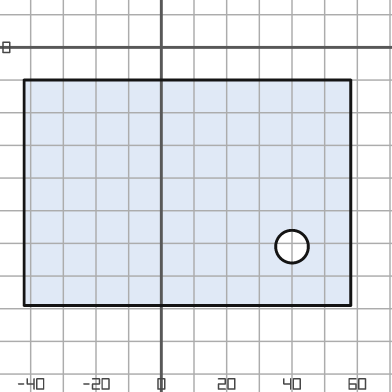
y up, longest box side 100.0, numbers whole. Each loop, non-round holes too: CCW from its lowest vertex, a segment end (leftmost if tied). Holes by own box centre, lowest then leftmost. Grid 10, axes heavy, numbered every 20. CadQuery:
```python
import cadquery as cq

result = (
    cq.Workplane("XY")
    .moveTo(-42.0, -79.0)
    .lineTo(58.0, -79.0)
    .lineTo(58.0, -10.0)
    .lineTo(-42.0, -10.0)
    .close()
    .moveTo(40.0, -61.0)
    .circle(5.0)
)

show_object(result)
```